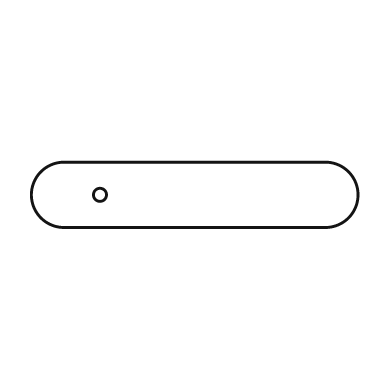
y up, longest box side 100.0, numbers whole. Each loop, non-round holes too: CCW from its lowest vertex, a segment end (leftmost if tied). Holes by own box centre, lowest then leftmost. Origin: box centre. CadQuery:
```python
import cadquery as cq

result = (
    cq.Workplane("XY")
    .moveTo(-40.0, -10.0)
    .lineTo(40.0, -10.0)
    .threePointArc((50.0, 0.0), (40.0, 10.0))
    .lineTo(-40.0, 10.0)
    .threePointArc((-50.0, 0.0), (-40.0, -10.0))
    .close()
    .moveTo(-29.0, 0.0)
    .circle(2.0)
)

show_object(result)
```